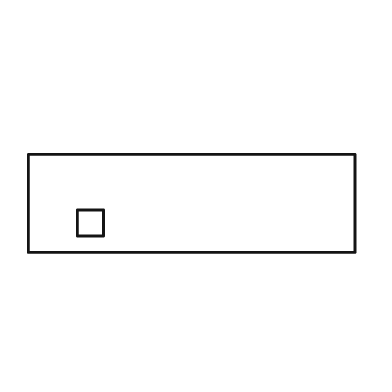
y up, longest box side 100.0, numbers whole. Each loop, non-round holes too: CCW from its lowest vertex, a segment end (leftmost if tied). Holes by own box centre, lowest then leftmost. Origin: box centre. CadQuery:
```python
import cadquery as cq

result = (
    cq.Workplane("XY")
    .moveTo(-50.0, -15.0)
    .lineTo(50.0, -15.0)
    .lineTo(50.0, 15.0)
    .lineTo(-50.0, 15.0)
    .close()
    .moveTo(-35.0, -10.0)
    .lineTo(-27.0, -10.0)
    .lineTo(-27.0, -2.0)
    .lineTo(-35.0, -2.0)
    .close()
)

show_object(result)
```